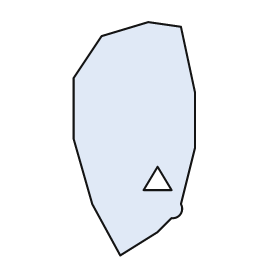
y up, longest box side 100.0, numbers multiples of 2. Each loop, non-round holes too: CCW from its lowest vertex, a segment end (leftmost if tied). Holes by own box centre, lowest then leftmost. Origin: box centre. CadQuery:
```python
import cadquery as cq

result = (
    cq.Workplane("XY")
    .moveTo(-6.0, -50.0)
    .lineTo(10.0, -40.0)
    .lineTo(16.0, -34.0)
    .threePointArc((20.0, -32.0), (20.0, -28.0))
    .lineTo(26.0, -4.0)
    .lineTo(26.0, 20.0)
    .lineTo(20.0, 48.0)
    .lineTo(6.0, 50.0)
    .lineTo(-14.0, 44.0)
    .lineTo(-26.0, 26.0)
    .lineTo(-26.0, 0.0)
    .lineTo(-18.0, -28.0)
    .close()
    .moveTo(4.0, -22.0)
    .lineTo(16.0, -22.0)
    .lineTo(10.0, -12.0)
    .close()
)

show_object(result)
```